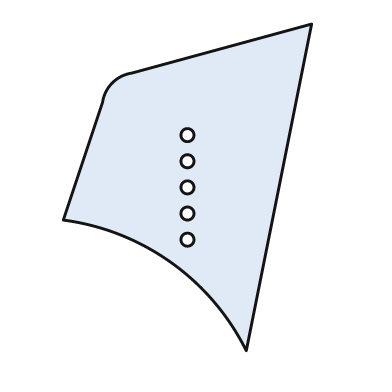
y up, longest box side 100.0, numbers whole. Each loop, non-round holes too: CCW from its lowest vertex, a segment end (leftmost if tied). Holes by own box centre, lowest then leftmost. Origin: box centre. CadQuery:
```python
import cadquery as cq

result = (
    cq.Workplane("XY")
    .moveTo(18.0, -50.0)
    .lineTo(38.0, 50.0)
    .lineTo(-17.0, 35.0)
    .threePointArc((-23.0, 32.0), (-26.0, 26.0))
    .lineTo(-38.0, -10.0)
    .threePointArc((-5.0, -23.0), (18.0, -50.0))
    .close()
    .moveTo(0.0, -16.0)
    .circle(2.0)
    .moveTo(0.0, -8.0)
    .circle(2.0)
    .moveTo(0.0, 0.0)
    .circle(2.0)
    .moveTo(0.0, 8.0)
    .circle(2.0)
    .moveTo(0.0, 16.0)
    .circle(2.0)
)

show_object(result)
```